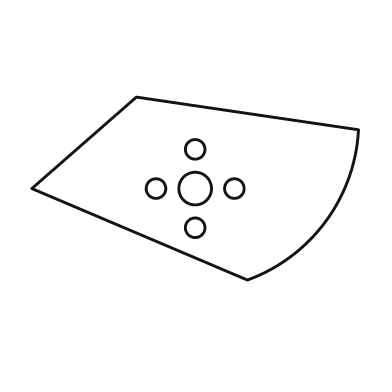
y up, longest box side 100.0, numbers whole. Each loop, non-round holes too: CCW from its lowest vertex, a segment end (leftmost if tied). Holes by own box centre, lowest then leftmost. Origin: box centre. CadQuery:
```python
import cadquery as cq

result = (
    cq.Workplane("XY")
    .moveTo(16.0, -28.0)
    .threePointArc((40.0, -10.0), (50.0, 18.0))
    .lineTo(-18.0, 28.0)
    .lineTo(-50.0, 0.0)
    .close()
    .moveTo(0.0, -12.0)
    .circle(3.0)
    .moveTo(-12.0, 0.0)
    .circle(3.0)
    .moveTo(0.0, 0.0)
    .circle(5.0)
    .moveTo(12.0, 0.0)
    .circle(3.0)
    .moveTo(0.0, 12.0)
    .circle(3.0)
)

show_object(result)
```